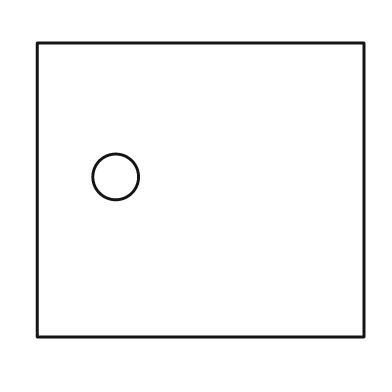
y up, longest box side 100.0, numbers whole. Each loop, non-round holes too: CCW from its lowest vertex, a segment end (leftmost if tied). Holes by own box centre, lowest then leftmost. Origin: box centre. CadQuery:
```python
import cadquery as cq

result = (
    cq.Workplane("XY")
    .moveTo(-50.0, -45.0)
    .lineTo(50.0, -45.0)
    .lineTo(50.0, 45.0)
    .lineTo(-50.0, 45.0)
    .close()
    .moveTo(-26.0, 4.0)
    .circle(7.0)
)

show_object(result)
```